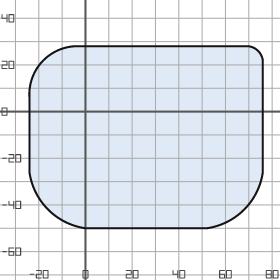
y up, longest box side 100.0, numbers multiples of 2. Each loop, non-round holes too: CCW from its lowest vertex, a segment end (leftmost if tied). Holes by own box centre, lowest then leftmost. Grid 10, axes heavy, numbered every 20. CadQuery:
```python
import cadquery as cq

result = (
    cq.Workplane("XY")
    .moveTo(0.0, -50.0)
    .lineTo(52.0, -50.0)
    .threePointArc((68.0, -42.0), (76.0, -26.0))
    .lineTo(76.0, 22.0)
    .threePointArc((74.0, 26.0), (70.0, 28.0))
    .lineTo(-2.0, 28.0)
    .threePointArc((-18.0, 22.0), (-24.0, 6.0))
    .lineTo(-24.0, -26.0)
    .threePointArc((-16.0, -42.0), (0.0, -50.0))
    .close()
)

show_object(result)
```